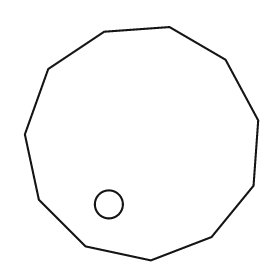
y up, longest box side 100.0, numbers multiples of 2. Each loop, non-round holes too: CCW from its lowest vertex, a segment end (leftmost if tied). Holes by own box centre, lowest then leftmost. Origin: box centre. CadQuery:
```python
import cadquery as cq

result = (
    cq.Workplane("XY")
    .moveTo(4.0, -50.0)
    .lineTo(30.0, -40.0)
    .lineTo(48.0, -18.0)
    .lineTo(50.0, 10.0)
    .lineTo(36.0, 36.0)
    .lineTo(12.0, 50.0)
    .lineTo(-16.0, 48.0)
    .lineTo(-40.0, 32.0)
    .lineTo(-50.0, 4.0)
    .lineTo(-44.0, -24.0)
    .lineTo(-24.0, -44.0)
    .close()
    .moveTo(-14.0, -26.0)
    .circle(6.0)
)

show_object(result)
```